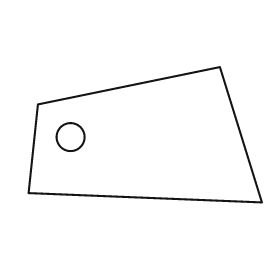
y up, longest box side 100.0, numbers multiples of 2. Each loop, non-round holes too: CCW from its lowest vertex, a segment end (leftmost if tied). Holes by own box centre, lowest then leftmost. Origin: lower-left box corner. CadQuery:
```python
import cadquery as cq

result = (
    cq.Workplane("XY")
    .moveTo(100.0, 0.0)
    .lineTo(82.0, 58.0)
    .lineTo(4.0, 42.0)
    .lineTo(0.0, 4.0)
    .close()
    .moveTo(18.0, 28.0)
    .circle(6.0)
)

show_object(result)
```